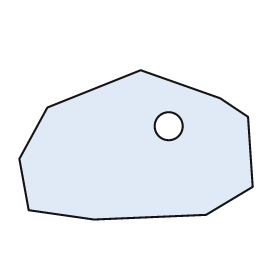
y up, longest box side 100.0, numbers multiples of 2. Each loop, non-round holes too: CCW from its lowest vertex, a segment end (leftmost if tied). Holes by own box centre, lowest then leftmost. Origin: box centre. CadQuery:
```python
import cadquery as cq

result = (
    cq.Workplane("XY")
    .moveTo(-18.0, -32.0)
    .lineTo(30.0, -30.0)
    .lineTo(50.0, -18.0)
    .lineTo(48.0, 12.0)
    .lineTo(36.0, 20.0)
    .lineTo(2.0, 32.0)
    .lineTo(-38.0, 16.0)
    .lineTo(-50.0, -6.0)
    .lineTo(-46.0, -28.0)
    .close()
    .moveTo(14.0, 8.0)
    .circle(6.0)
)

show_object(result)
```